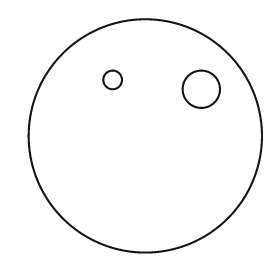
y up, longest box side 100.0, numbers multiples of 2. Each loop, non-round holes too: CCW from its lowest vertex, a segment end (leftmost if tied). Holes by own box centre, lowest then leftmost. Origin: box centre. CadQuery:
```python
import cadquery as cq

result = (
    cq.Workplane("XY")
    .moveTo(0.0, 0.0)
    .circle(50.0)
    .moveTo(24.0, 20.0)
    .circle(8.0)
    .moveTo(-14.0, 24.0)
    .circle(4.0)
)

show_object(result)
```